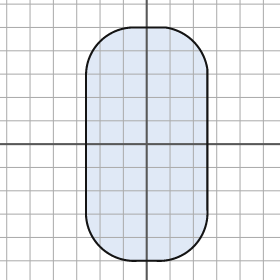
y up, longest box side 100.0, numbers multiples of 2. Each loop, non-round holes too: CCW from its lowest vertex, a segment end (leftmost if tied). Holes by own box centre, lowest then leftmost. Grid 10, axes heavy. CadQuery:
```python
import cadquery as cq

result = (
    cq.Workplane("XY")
    .moveTo(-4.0, -50.0)
    .lineTo(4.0, -50.0)
    .threePointArc((20.0, -44.0), (26.0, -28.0))
    .lineTo(26.0, 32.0)
    .threePointArc((20.0, 44.0), (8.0, 50.0))
    .lineTo(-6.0, 50.0)
    .threePointArc((-20.0, 44.0), (-26.0, 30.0))
    .lineTo(-26.0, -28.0)
    .threePointArc((-20.0, -44.0), (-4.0, -50.0))
    .close()
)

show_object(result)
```